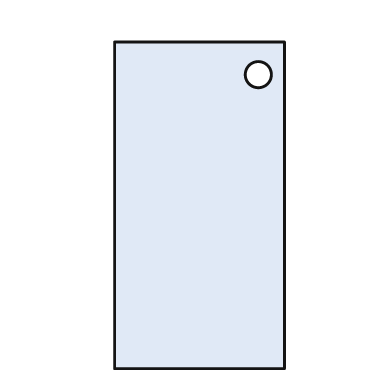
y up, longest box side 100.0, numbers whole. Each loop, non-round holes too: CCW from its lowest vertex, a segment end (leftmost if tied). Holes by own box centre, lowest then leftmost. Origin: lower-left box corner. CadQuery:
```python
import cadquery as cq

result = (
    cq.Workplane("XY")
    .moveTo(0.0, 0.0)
    .lineTo(52.0, 0.0)
    .lineTo(52.0, 100.0)
    .lineTo(0.0, 100.0)
    .close()
    .moveTo(44.0, 90.0)
    .circle(4.0)
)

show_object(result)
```